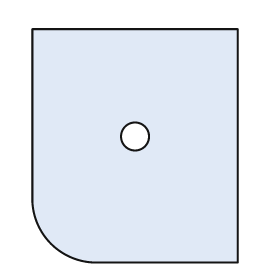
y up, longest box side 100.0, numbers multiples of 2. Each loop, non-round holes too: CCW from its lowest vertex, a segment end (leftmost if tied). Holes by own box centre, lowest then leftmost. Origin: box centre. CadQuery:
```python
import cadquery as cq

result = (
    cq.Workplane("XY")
    .moveTo(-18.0, -50.0)
    .lineTo(44.0, -50.0)
    .lineTo(44.0, 50.0)
    .lineTo(-44.0, 50.0)
    .lineTo(-44.0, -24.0)
    .threePointArc((-36.0, -42.0), (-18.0, -50.0))
    .close()
    .moveTo(0.0, 4.0)
    .circle(6.0)
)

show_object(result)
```